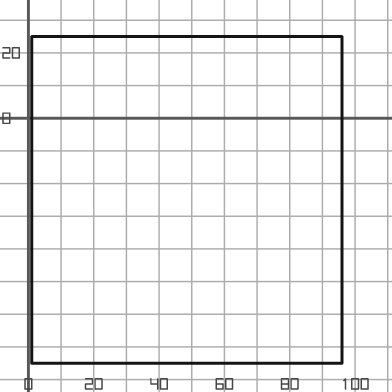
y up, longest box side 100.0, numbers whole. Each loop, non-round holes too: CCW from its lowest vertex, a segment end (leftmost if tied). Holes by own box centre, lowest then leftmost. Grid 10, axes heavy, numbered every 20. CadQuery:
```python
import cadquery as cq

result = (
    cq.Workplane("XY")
    .moveTo(1.0, -75.0)
    .lineTo(96.0, -75.0)
    .lineTo(96.0, 25.0)
    .lineTo(1.0, 25.0)
    .close()
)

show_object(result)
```